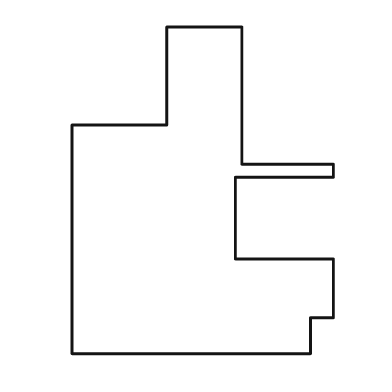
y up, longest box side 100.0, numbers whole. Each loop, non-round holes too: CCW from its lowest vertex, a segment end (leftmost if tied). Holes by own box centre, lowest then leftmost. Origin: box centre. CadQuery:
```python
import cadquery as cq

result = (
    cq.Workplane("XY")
    .moveTo(-40.0, -50.0)
    .lineTo(33.0, -50.0)
    .lineTo(33.0, -39.0)
    .lineTo(40.0, -39.0)
    .lineTo(40.0, -21.0)
    .lineTo(10.0, -21.0)
    .lineTo(10.0, 4.0)
    .lineTo(40.0, 4.0)
    .lineTo(40.0, 8.0)
    .lineTo(12.0, 8.0)
    .lineTo(12.0, 50.0)
    .lineTo(-11.0, 50.0)
    .lineTo(-11.0, 20.0)
    .lineTo(-40.0, 20.0)
    .close()
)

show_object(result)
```